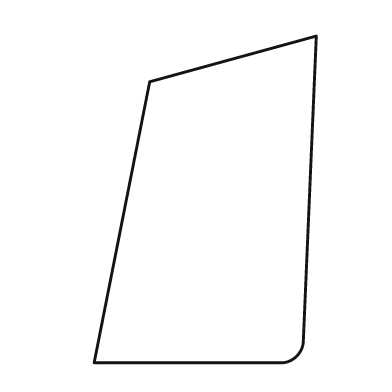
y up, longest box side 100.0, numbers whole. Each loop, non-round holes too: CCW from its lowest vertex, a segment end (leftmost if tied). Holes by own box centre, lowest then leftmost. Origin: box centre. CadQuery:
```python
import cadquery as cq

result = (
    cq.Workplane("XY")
    .moveTo(-34.0, -50.0)
    .lineTo(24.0, -50.0)
    .threePointArc((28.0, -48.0), (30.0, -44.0))
    .lineTo(34.0, 50.0)
    .lineTo(-17.0, 36.0)
    .close()
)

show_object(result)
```